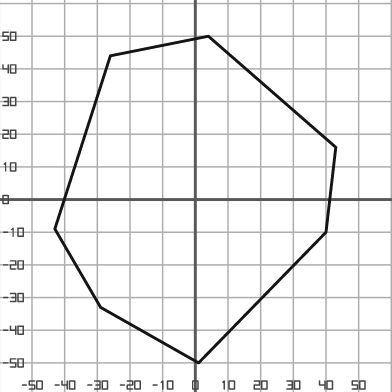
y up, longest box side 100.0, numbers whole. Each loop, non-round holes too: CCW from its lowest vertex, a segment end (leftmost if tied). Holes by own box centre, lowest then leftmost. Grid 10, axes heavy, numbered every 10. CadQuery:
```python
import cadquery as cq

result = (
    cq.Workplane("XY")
    .moveTo(1.0, -50.0)
    .lineTo(40.0, -10.0)
    .lineTo(43.0, 16.0)
    .lineTo(4.0, 50.0)
    .lineTo(-26.0, 44.0)
    .lineTo(-43.0, -9.0)
    .lineTo(-29.0, -33.0)
    .close()
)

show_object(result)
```